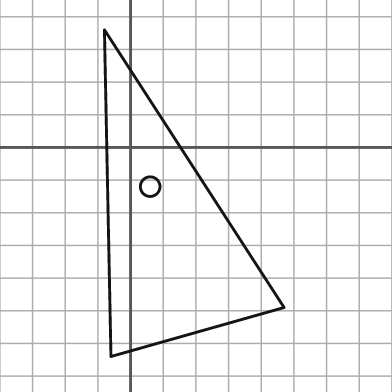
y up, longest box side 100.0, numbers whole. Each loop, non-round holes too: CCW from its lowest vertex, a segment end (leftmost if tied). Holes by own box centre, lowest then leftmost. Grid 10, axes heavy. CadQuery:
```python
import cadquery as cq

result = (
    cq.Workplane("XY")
    .moveTo(-6.0, -64.0)
    .lineTo(47.0, -49.0)
    .lineTo(-8.0, 36.0)
    .close()
    .moveTo(6.0, -12.0)
    .circle(3.0)
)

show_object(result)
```